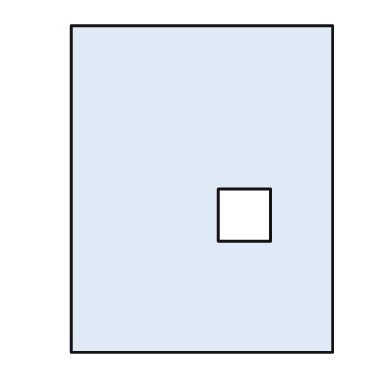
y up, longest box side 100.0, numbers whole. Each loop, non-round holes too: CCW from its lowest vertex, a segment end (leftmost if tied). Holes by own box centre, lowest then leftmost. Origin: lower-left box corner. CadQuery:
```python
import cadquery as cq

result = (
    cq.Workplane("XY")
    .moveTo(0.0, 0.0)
    .lineTo(80.0, 0.0)
    .lineTo(80.0, 100.0)
    .lineTo(0.0, 100.0)
    .close()
    .moveTo(45.0, 34.0)
    .lineTo(61.0, 34.0)
    .lineTo(61.0, 50.0)
    .lineTo(45.0, 50.0)
    .close()
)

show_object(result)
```